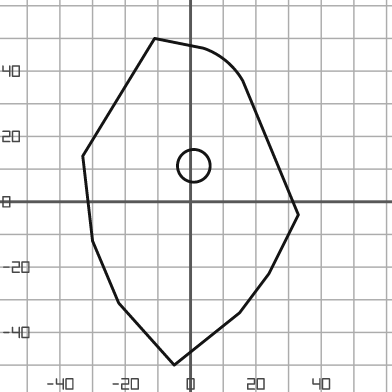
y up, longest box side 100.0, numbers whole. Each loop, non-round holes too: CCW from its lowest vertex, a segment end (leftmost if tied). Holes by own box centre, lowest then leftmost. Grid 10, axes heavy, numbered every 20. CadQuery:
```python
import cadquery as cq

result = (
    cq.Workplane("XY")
    .moveTo(-5.0, -50.0)
    .lineTo(15.0, -34.0)
    .lineTo(24.0, -22.0)
    .lineTo(33.0, -4.0)
    .lineTo(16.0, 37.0)
    .threePointArc((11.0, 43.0), (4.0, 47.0))
    .lineTo(-11.0, 50.0)
    .lineTo(-33.0, 14.0)
    .lineTo(-30.0, -12.0)
    .lineTo(-22.0, -31.0)
    .close()
    .moveTo(1.0, 11.0)
    .circle(5.0)
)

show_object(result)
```